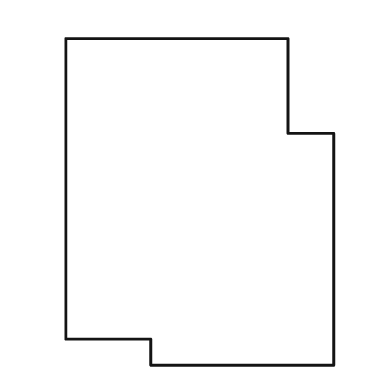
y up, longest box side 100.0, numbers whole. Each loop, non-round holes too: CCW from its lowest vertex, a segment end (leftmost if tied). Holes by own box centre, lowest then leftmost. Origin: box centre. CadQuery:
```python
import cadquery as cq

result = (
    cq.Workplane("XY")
    .moveTo(-15.0, -50.0)
    .lineTo(41.0, -50.0)
    .lineTo(41.0, 21.0)
    .lineTo(27.0, 21.0)
    .lineTo(27.0, 50.0)
    .lineTo(-41.0, 50.0)
    .lineTo(-41.0, -42.0)
    .lineTo(-15.0, -42.0)
    .close()
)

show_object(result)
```